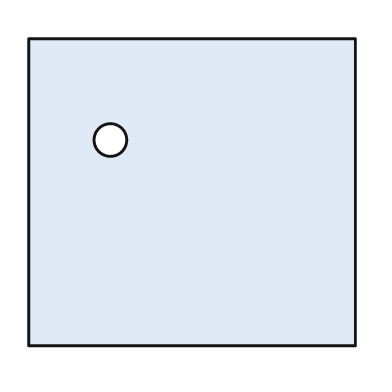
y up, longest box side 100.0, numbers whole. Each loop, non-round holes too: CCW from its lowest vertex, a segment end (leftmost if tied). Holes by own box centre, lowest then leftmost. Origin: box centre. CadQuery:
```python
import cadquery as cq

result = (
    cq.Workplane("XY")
    .moveTo(-50.0, -47.0)
    .lineTo(50.0, -47.0)
    .lineTo(50.0, 47.0)
    .lineTo(-50.0, 47.0)
    .close()
    .moveTo(-25.0, 16.0)
    .circle(5.0)
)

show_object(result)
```